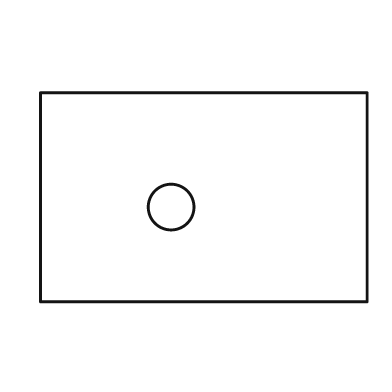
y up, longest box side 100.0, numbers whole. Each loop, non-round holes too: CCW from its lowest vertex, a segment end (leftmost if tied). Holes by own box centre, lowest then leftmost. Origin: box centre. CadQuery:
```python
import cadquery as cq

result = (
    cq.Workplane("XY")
    .moveTo(-50.0, -32.0)
    .lineTo(50.0, -32.0)
    .lineTo(50.0, 32.0)
    .lineTo(-50.0, 32.0)
    .close()
    .moveTo(-10.0, -3.0)
    .circle(7.0)
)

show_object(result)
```